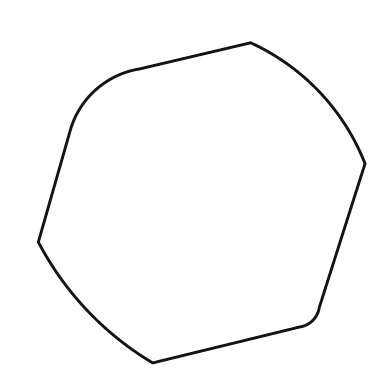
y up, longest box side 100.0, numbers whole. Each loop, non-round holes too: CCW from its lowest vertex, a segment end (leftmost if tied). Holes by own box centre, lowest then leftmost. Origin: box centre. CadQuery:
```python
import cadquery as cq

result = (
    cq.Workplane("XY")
    .moveTo(-15.0, -49.0)
    .lineTo(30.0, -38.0)
    .threePointArc((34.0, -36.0), (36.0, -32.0))
    .lineTo(50.0, 12.0)
    .threePointArc((36.0, 34.0), (15.0, 49.0))
    .lineTo(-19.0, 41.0)
    .threePointArc((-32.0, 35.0), (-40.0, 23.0))
    .lineTo(-50.0, -12.0)
    .threePointArc((-35.0, -33.0), (-15.0, -49.0))
    .close()
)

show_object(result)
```